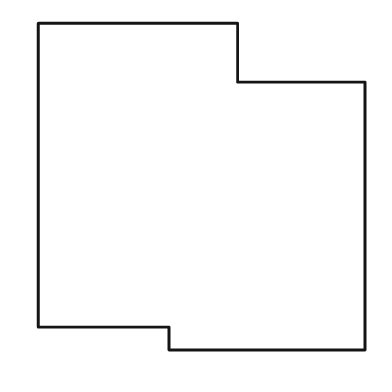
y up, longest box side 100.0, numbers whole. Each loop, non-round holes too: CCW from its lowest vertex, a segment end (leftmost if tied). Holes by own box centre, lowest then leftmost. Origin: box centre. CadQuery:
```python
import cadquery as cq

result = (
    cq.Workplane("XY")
    .moveTo(-10.0, -50.0)
    .lineTo(50.0, -50.0)
    .lineTo(50.0, 32.0)
    .lineTo(11.0, 32.0)
    .lineTo(11.0, 50.0)
    .lineTo(-50.0, 50.0)
    .lineTo(-50.0, -43.0)
    .lineTo(-10.0, -43.0)
    .close()
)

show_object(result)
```